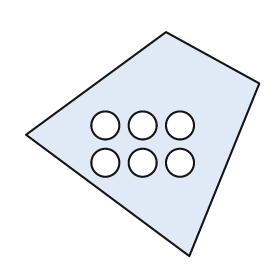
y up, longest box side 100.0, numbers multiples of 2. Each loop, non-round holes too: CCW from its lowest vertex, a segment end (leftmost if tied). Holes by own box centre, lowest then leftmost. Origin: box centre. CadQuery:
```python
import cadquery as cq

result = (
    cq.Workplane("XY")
    .moveTo(20.0, -48.0)
    .lineTo(50.0, 26.0)
    .lineTo(10.0, 48.0)
    .lineTo(-50.0, 4.0)
    .close()
    .moveTo(-16.0, -8.0)
    .circle(6.0)
    .moveTo(0.0, -8.0)
    .circle(6.0)
    .moveTo(16.0, -8.0)
    .circle(6.0)
    .moveTo(-16.0, 8.0)
    .circle(6.0)
    .moveTo(0.0, 8.0)
    .circle(6.0)
    .moveTo(16.0, 8.0)
    .circle(6.0)
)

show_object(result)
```